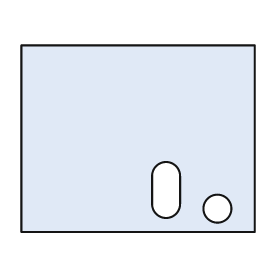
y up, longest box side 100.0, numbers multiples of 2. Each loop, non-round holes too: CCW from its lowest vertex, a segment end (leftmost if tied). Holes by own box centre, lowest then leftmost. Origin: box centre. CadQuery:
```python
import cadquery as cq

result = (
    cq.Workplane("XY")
    .moveTo(-50.0, -40.0)
    .lineTo(50.0, -40.0)
    .lineTo(50.0, 40.0)
    .lineTo(-50.0, 40.0)
    .close()
    .moveTo(34.0, -30.0)
    .circle(6.0)
    .moveTo(6.0, -28.0)
    .threePointArc((12.0, -34.0), (18.0, -28.0))
    .lineTo(18.0, -16.0)
    .threePointArc((12.0, -10.0), (6.0, -16.0))
    .close()
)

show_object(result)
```